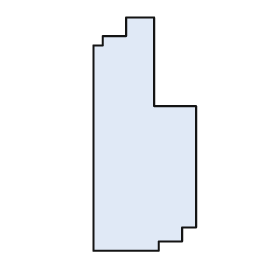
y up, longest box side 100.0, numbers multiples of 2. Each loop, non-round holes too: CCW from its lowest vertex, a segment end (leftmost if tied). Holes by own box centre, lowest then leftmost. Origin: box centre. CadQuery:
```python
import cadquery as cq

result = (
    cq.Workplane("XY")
    .moveTo(-22.0, -50.0)
    .lineTo(6.0, -50.0)
    .lineTo(6.0, -46.0)
    .lineTo(16.0, -46.0)
    .lineTo(16.0, -40.0)
    .lineTo(22.0, -40.0)
    .lineTo(22.0, 12.0)
    .lineTo(4.0, 12.0)
    .lineTo(4.0, 50.0)
    .lineTo(-8.0, 50.0)
    .lineTo(-8.0, 42.0)
    .lineTo(-18.0, 42.0)
    .lineTo(-18.0, 38.0)
    .lineTo(-22.0, 38.0)
    .close()
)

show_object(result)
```